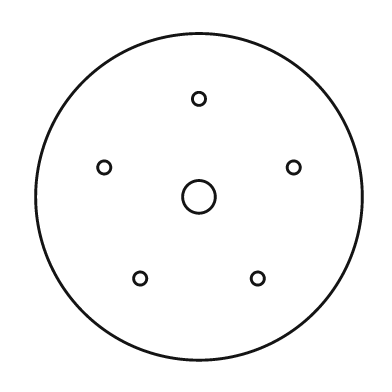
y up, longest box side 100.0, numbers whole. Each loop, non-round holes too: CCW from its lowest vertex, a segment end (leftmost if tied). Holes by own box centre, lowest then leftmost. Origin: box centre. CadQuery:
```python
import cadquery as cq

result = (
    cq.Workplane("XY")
    .moveTo(0.0, 0.0)
    .circle(50.0)
    .moveTo(-18.0, -25.0)
    .circle(2.0)
    .moveTo(18.0, -25.0)
    .circle(2.0)
    .moveTo(0.0, 0.0)
    .circle(5.0)
    .moveTo(-29.0, 9.0)
    .circle(2.0)
    .moveTo(29.0, 9.0)
    .circle(2.0)
    .moveTo(0.0, 30.0)
    .circle(2.0)
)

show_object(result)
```